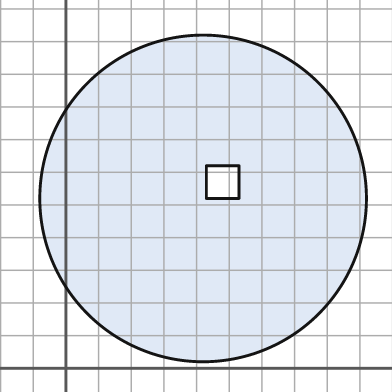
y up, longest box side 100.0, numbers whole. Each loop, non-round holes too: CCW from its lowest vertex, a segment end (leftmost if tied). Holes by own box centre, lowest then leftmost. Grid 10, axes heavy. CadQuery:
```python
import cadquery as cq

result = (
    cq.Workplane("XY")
    .moveTo(42.0, 52.0)
    .circle(50.0)
    .moveTo(43.0, 52.0)
    .lineTo(53.0, 52.0)
    .lineTo(53.0, 62.0)
    .lineTo(43.0, 62.0)
    .close()
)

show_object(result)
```